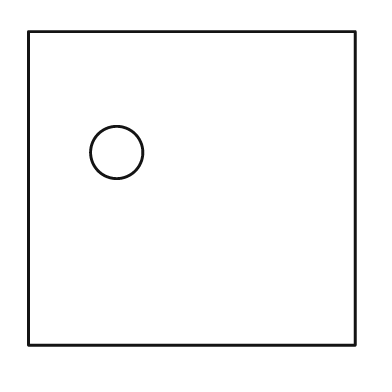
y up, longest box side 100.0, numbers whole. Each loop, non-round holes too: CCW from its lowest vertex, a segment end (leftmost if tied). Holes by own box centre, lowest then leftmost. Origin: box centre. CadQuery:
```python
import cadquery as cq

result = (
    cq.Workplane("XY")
    .moveTo(-50.0, -48.0)
    .lineTo(50.0, -48.0)
    .lineTo(50.0, 48.0)
    .lineTo(-50.0, 48.0)
    .close()
    .moveTo(-23.0, 11.0)
    .circle(8.0)
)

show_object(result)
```